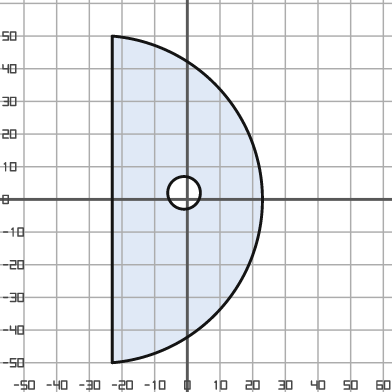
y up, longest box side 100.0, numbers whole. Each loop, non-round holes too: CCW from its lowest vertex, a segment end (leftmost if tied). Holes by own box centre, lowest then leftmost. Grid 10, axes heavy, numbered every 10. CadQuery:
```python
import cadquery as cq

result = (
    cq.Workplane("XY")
    .moveTo(-23.0, -50.0)
    .threePointArc((23.0, 0.0), (-23.0, 50.0))
    .close()
    .moveTo(-1.0, 2.0)
    .circle(5.0)
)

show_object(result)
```